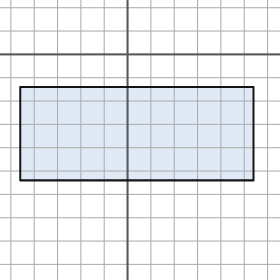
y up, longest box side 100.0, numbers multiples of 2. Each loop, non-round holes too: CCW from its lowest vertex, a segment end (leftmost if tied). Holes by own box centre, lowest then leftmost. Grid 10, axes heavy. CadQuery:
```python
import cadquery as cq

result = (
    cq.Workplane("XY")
    .moveTo(-46.0, -54.0)
    .lineTo(54.0, -54.0)
    .lineTo(54.0, -14.0)
    .lineTo(-46.0, -14.0)
    .close()
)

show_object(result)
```